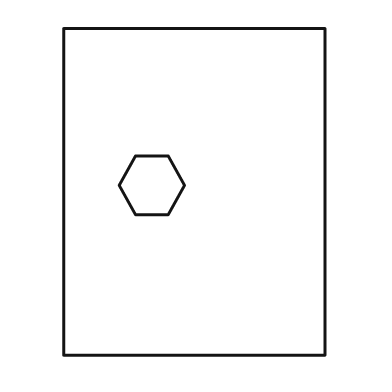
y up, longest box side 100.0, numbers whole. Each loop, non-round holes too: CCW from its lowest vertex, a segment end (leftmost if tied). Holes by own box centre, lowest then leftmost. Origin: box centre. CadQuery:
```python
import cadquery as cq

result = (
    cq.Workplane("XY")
    .moveTo(-40.0, -50.0)
    .lineTo(40.0, -50.0)
    .lineTo(40.0, 50.0)
    .lineTo(-40.0, 50.0)
    .close()
    .moveTo(-18.0, -7.0)
    .lineTo(-8.0, -7.0)
    .lineTo(-3.0, 2.0)
    .lineTo(-8.0, 11.0)
    .lineTo(-18.0, 11.0)
    .lineTo(-23.0, 2.0)
    .close()
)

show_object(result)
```